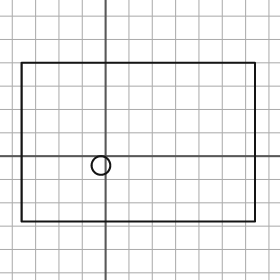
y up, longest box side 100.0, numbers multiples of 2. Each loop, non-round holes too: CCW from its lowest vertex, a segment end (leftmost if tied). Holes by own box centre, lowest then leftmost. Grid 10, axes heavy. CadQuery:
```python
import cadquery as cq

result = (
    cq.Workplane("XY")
    .moveTo(-36.0, -28.0)
    .lineTo(64.0, -28.0)
    .lineTo(64.0, 40.0)
    .lineTo(-36.0, 40.0)
    .close()
    .moveTo(-2.0, -4.0)
    .circle(4.0)
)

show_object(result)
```